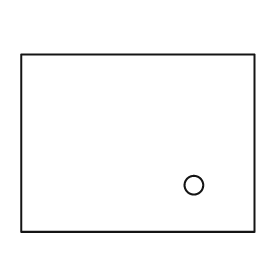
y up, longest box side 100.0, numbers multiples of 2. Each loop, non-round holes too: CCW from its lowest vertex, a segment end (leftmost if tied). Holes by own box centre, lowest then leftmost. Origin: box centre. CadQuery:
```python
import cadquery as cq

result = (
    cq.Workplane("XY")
    .moveTo(-50.0, -38.0)
    .lineTo(50.0, -38.0)
    .lineTo(50.0, 38.0)
    .lineTo(-50.0, 38.0)
    .close()
    .moveTo(24.0, -18.0)
    .circle(4.0)
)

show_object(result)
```